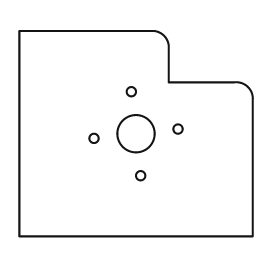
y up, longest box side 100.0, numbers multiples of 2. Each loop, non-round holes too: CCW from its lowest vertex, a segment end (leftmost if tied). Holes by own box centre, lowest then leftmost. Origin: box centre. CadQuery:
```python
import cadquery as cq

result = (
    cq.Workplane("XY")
    .moveTo(-50.0, -44.0)
    .lineTo(50.0, -44.0)
    .lineTo(50.0, 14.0)
    .threePointArc((48.0, 20.0), (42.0, 22.0))
    .lineTo(14.0, 22.0)
    .lineTo(14.0, 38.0)
    .threePointArc((12.0, 42.0), (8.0, 44.0))
    .lineTo(-50.0, 44.0)
    .close()
    .moveTo(2.0, -18.0)
    .circle(2.0)
    .moveTo(-18.0, -2.0)
    .circle(2.0)
    .moveTo(0.0, 0.0)
    .circle(8.0)
    .moveTo(18.0, 2.0)
    .circle(2.0)
    .moveTo(-2.0, 18.0)
    .circle(2.0)
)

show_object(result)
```